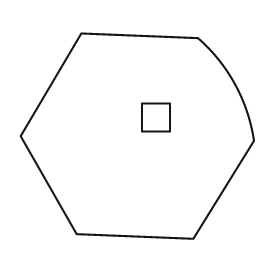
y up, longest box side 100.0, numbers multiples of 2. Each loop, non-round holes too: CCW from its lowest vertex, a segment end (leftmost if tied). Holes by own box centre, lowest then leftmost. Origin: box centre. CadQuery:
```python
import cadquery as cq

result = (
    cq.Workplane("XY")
    .moveTo(24.0, -44.0)
    .lineTo(50.0, -2.0)
    .threePointArc((42.0, 22.0), (26.0, 42.0))
    .lineTo(-24.0, 44.0)
    .lineTo(-50.0, 0.0)
    .lineTo(-26.0, -42.0)
    .close()
    .moveTo(2.0, 2.0)
    .lineTo(14.0, 2.0)
    .lineTo(14.0, 14.0)
    .lineTo(2.0, 14.0)
    .close()
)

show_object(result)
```